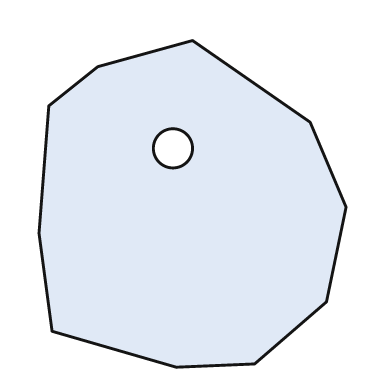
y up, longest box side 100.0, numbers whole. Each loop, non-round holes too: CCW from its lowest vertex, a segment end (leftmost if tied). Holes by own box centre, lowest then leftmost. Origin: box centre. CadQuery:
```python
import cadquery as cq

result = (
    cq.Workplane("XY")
    .moveTo(-5.0, -50.0)
    .lineTo(19.0, -49.0)
    .lineTo(41.0, -30.0)
    .lineTo(47.0, -1.0)
    .lineTo(36.0, 25.0)
    .lineTo(0.0, 50.0)
    .lineTo(-29.0, 42.0)
    .lineTo(-44.0, 30.0)
    .lineTo(-47.0, -9.0)
    .lineTo(-43.0, -39.0)
    .close()
    .moveTo(-6.0, 17.0)
    .circle(6.0)
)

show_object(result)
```